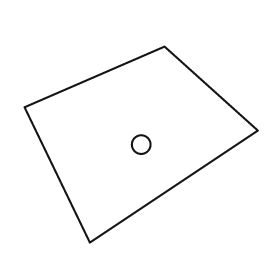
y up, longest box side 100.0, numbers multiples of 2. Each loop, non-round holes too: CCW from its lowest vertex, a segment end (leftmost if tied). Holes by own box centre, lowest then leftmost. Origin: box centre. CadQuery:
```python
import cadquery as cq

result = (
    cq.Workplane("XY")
    .moveTo(-22.0, -42.0)
    .lineTo(50.0, 6.0)
    .lineTo(10.0, 42.0)
    .lineTo(-50.0, 16.0)
    .close()
    .moveTo(0.0, 0.0)
    .circle(4.0)
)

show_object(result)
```